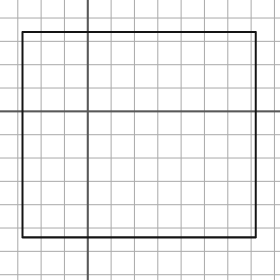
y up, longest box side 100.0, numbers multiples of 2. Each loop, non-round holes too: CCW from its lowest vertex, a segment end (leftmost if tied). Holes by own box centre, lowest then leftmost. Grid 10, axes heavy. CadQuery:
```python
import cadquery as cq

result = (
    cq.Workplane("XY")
    .moveTo(-28.0, -54.0)
    .lineTo(72.0, -54.0)
    .lineTo(72.0, 34.0)
    .lineTo(-28.0, 34.0)
    .close()
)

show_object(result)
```